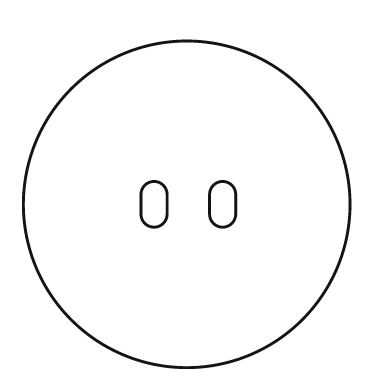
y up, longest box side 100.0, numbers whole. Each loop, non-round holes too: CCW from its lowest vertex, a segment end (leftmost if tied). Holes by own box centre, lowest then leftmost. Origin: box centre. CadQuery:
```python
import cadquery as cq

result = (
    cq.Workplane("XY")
    .moveTo(0.0, 0.0)
    .circle(50.0)
    .moveTo(-14.0, -3.0)
    .threePointArc((-10.0, -7.0), (-6.0, -3.0))
    .lineTo(-6.0, 3.0)
    .threePointArc((-10.0, 7.0), (-14.0, 3.0))
    .close()
    .moveTo(7.0, -3.0)
    .threePointArc((11.0, -7.0), (15.0, -3.0))
    .lineTo(15.0, 3.0)
    .threePointArc((11.0, 7.0), (7.0, 3.0))
    .close()
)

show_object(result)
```